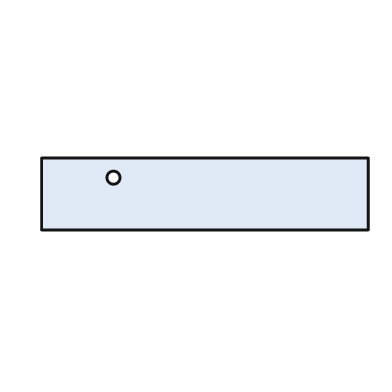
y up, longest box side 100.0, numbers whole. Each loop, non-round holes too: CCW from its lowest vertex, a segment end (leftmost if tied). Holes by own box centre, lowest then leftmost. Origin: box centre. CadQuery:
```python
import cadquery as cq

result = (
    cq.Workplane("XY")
    .moveTo(-50.0, -11.0)
    .lineTo(50.0, -11.0)
    .lineTo(50.0, 11.0)
    .lineTo(-50.0, 11.0)
    .close()
    .moveTo(-28.0, 5.0)
    .circle(2.0)
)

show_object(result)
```